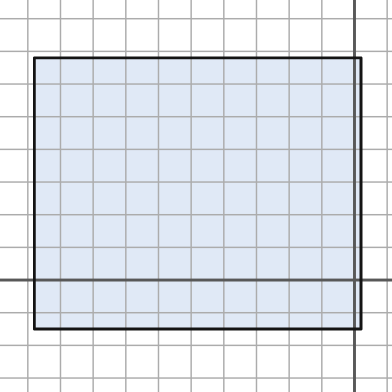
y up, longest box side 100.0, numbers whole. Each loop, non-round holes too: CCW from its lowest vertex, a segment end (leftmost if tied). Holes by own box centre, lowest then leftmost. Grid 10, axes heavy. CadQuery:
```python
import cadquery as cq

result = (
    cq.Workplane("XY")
    .moveTo(-98.0, -15.0)
    .lineTo(2.0, -15.0)
    .lineTo(2.0, 68.0)
    .lineTo(-98.0, 68.0)
    .close()
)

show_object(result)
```